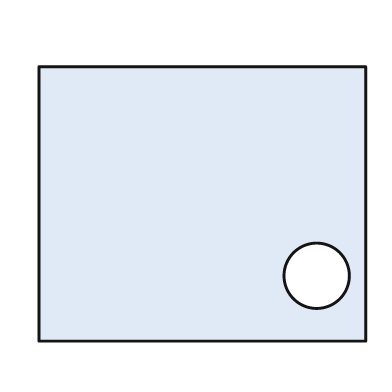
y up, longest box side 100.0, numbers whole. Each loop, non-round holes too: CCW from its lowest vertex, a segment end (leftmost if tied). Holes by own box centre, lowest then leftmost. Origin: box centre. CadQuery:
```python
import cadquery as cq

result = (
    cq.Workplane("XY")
    .moveTo(-50.0, -42.0)
    .lineTo(50.0, -42.0)
    .lineTo(50.0, 42.0)
    .lineTo(-50.0, 42.0)
    .close()
    .moveTo(35.0, -22.0)
    .circle(10.0)
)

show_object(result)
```